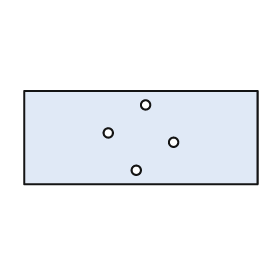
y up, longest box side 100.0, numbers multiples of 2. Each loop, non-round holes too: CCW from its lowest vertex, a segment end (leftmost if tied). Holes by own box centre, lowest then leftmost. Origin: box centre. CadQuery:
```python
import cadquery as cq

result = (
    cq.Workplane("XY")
    .moveTo(-50.0, -20.0)
    .lineTo(50.0, -20.0)
    .lineTo(50.0, 20.0)
    .lineTo(-50.0, 20.0)
    .close()
    .moveTo(-2.0, -14.0)
    .circle(2.0)
    .moveTo(14.0, -2.0)
    .circle(2.0)
    .moveTo(-14.0, 2.0)
    .circle(2.0)
    .moveTo(2.0, 14.0)
    .circle(2.0)
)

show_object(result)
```